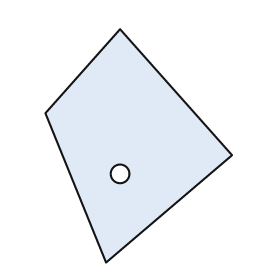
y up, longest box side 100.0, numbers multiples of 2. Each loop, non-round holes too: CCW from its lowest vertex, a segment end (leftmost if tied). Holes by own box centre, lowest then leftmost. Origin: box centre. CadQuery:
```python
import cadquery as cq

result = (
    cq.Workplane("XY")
    .moveTo(-14.0, -50.0)
    .lineTo(40.0, -4.0)
    .lineTo(-8.0, 50.0)
    .lineTo(-40.0, 14.0)
    .close()
    .moveTo(-8.0, -12.0)
    .circle(4.0)
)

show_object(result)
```